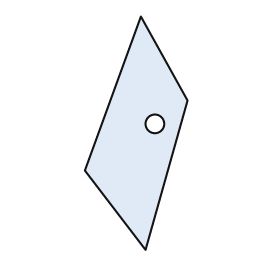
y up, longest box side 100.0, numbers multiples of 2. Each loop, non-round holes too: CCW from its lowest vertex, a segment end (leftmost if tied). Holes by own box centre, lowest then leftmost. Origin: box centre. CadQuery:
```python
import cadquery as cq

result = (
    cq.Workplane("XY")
    .moveTo(4.0, -50.0)
    .lineTo(22.0, 14.0)
    .lineTo(2.0, 50.0)
    .lineTo(-22.0, -16.0)
    .close()
    .moveTo(8.0, 4.0)
    .circle(4.0)
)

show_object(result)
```